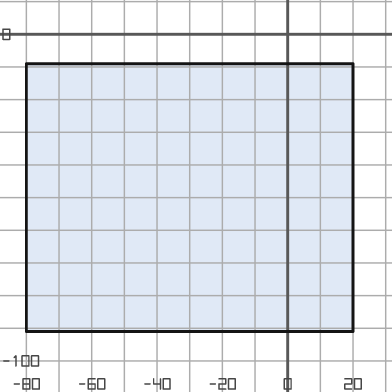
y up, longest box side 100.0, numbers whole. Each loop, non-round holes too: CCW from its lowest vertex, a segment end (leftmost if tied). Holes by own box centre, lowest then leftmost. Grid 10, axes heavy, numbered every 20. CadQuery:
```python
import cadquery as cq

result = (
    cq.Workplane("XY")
    .moveTo(-80.0, -91.0)
    .lineTo(20.0, -91.0)
    .lineTo(20.0, -9.0)
    .lineTo(-80.0, -9.0)
    .close()
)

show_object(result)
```